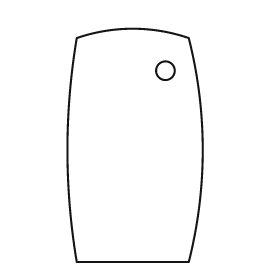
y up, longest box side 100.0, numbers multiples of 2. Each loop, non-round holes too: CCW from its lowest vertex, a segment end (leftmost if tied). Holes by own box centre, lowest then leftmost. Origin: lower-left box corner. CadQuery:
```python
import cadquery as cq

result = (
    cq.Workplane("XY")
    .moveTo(4.0, 0.0)
    .lineTo(52.0, 0.0)
    .threePointArc((58.0, 48.0), (52.0, 96.0))
    .threePointArc((28.0, 100.0), (4.0, 96.0))
    .threePointArc((0.0, 48.0), (4.0, 0.0))
    .close()
    .moveTo(42.0, 82.0)
    .circle(4.0)
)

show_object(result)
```